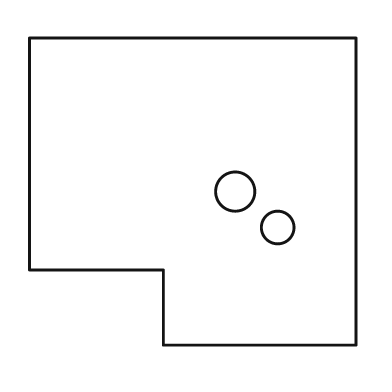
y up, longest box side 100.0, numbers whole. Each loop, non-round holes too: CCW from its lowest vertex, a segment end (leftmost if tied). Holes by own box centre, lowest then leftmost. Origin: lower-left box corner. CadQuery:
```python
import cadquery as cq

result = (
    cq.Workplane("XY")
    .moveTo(41.0, 0.0)
    .lineTo(100.0, 0.0)
    .lineTo(100.0, 94.0)
    .lineTo(0.0, 94.0)
    .lineTo(0.0, 23.0)
    .lineTo(41.0, 23.0)
    .close()
    .moveTo(76.0, 36.0)
    .circle(5.0)
    .moveTo(63.0, 47.0)
    .circle(6.0)
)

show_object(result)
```